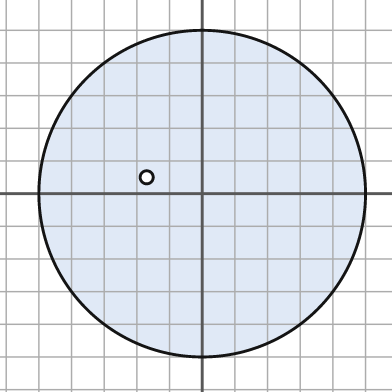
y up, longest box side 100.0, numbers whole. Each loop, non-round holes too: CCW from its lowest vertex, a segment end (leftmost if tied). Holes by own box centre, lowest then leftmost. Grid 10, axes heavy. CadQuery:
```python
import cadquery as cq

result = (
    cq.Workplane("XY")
    .moveTo(0.0, 0.0)
    .circle(50.0)
    .moveTo(-17.0, 5.0)
    .circle(2.0)
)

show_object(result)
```